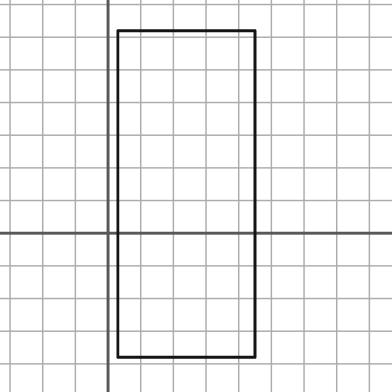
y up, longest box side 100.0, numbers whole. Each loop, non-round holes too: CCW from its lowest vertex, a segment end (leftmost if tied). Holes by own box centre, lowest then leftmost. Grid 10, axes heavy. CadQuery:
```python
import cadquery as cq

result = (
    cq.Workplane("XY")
    .moveTo(3.0, -38.0)
    .lineTo(45.0, -38.0)
    .lineTo(45.0, 62.0)
    .lineTo(3.0, 62.0)
    .close()
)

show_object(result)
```